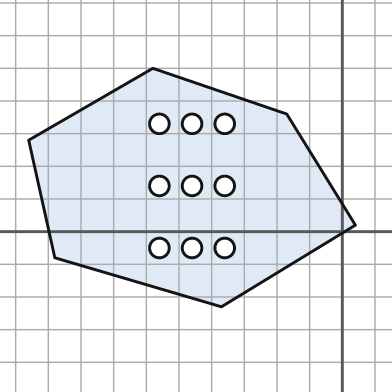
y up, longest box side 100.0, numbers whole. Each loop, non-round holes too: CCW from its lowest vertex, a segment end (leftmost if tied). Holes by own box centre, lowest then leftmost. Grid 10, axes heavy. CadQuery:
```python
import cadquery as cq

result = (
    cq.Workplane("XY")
    .moveTo(-37.0, -23.0)
    .lineTo(4.0, 2.0)
    .lineTo(-17.0, 36.0)
    .lineTo(-58.0, 50.0)
    .lineTo(-96.0, 28.0)
    .lineTo(-88.0, -8.0)
    .close()
    .moveTo(-56.0, -5.0)
    .circle(3.0)
    .moveTo(-46.0, -5.0)
    .circle(3.0)
    .moveTo(-36.0, -5.0)
    .circle(3.0)
    .moveTo(-56.0, 14.0)
    .circle(3.0)
    .moveTo(-46.0, 14.0)
    .circle(3.0)
    .moveTo(-36.0, 14.0)
    .circle(3.0)
    .moveTo(-56.0, 33.0)
    .circle(3.0)
    .moveTo(-46.0, 33.0)
    .circle(3.0)
    .moveTo(-36.0, 33.0)
    .circle(3.0)
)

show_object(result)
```